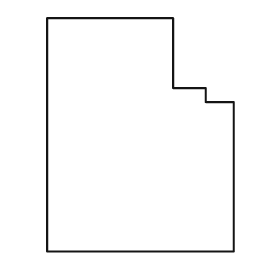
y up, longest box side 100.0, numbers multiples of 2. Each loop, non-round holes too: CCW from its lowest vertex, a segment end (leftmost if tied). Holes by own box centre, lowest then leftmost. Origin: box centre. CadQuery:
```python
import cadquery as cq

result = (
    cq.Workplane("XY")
    .moveTo(-40.0, -50.0)
    .lineTo(40.0, -50.0)
    .lineTo(40.0, 14.0)
    .lineTo(28.0, 14.0)
    .lineTo(28.0, 20.0)
    .lineTo(14.0, 20.0)
    .lineTo(14.0, 50.0)
    .lineTo(-40.0, 50.0)
    .close()
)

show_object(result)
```